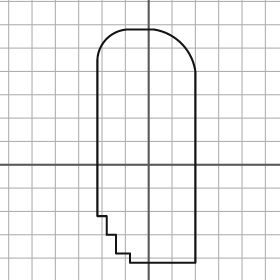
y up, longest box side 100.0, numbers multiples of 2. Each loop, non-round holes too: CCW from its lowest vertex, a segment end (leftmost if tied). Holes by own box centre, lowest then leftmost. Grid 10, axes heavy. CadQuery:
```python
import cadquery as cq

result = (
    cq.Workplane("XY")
    .moveTo(-8.0, -42.0)
    .lineTo(20.0, -42.0)
    .lineTo(20.0, 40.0)
    .threePointArc((14.0, 52.0), (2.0, 58.0))
    .lineTo(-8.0, 58.0)
    .threePointArc((-18.0, 54.0), (-22.0, 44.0))
    .lineTo(-22.0, -22.0)
    .lineTo(-18.0, -22.0)
    .lineTo(-18.0, -30.0)
    .lineTo(-14.0, -30.0)
    .lineTo(-14.0, -38.0)
    .lineTo(-8.0, -38.0)
    .close()
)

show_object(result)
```